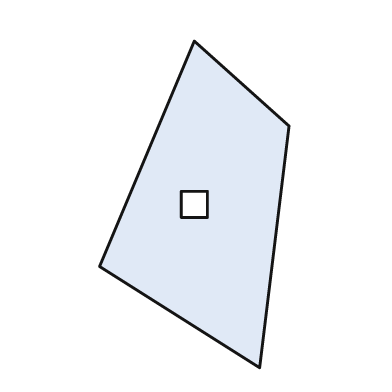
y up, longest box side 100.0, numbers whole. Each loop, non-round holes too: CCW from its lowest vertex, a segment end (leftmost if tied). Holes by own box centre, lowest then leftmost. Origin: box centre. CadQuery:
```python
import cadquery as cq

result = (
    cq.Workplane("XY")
    .moveTo(20.0, -50.0)
    .lineTo(29.0, 24.0)
    .lineTo(0.0, 50.0)
    .lineTo(-29.0, -19.0)
    .close()
    .moveTo(-4.0, -4.0)
    .lineTo(4.0, -4.0)
    .lineTo(4.0, 4.0)
    .lineTo(-4.0, 4.0)
    .close()
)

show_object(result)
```